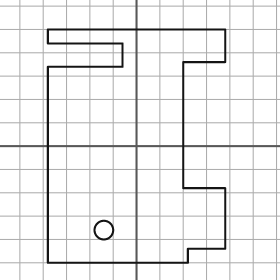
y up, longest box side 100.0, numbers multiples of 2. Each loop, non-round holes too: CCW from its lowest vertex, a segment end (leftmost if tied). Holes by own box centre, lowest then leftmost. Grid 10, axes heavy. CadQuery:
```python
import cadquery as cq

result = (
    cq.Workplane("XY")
    .moveTo(-38.0, -50.0)
    .lineTo(22.0, -50.0)
    .lineTo(22.0, -44.0)
    .lineTo(38.0, -44.0)
    .lineTo(38.0, -18.0)
    .lineTo(20.0, -18.0)
    .lineTo(20.0, 36.0)
    .lineTo(38.0, 36.0)
    .lineTo(38.0, 50.0)
    .lineTo(-38.0, 50.0)
    .lineTo(-38.0, 44.0)
    .lineTo(-6.0, 44.0)
    .lineTo(-6.0, 34.0)
    .lineTo(-38.0, 34.0)
    .close()
    .moveTo(-14.0, -36.0)
    .circle(4.0)
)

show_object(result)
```